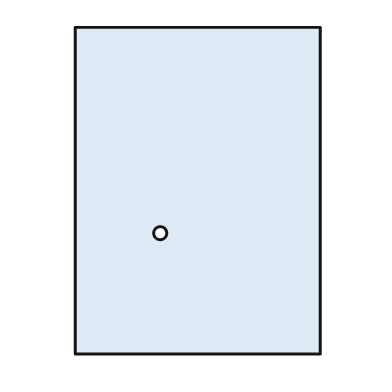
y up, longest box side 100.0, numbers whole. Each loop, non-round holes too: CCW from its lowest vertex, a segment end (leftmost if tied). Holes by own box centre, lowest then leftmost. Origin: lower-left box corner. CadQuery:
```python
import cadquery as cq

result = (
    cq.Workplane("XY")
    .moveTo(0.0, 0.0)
    .lineTo(75.0, 0.0)
    .lineTo(75.0, 100.0)
    .lineTo(0.0, 100.0)
    .close()
    .moveTo(26.0, 37.0)
    .circle(2.0)
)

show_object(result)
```